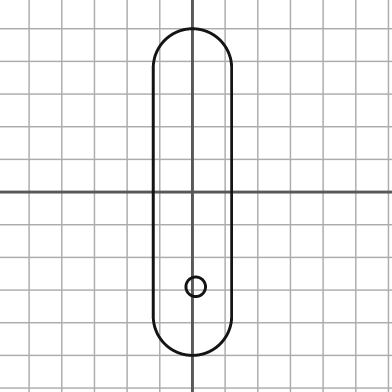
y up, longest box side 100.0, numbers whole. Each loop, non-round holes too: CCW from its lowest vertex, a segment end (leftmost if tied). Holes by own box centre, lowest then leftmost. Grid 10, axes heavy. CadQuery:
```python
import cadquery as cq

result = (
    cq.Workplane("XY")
    .moveTo(-12.0, -38.0)
    .threePointArc((0.0, -50.0), (12.0, -38.0))
    .lineTo(12.0, 38.0)
    .threePointArc((0.0, 50.0), (-12.0, 38.0))
    .close()
    .moveTo(1.0, -29.0)
    .circle(3.0)
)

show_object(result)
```